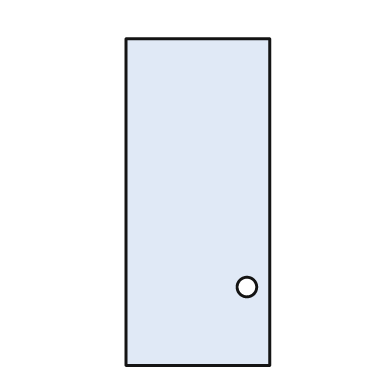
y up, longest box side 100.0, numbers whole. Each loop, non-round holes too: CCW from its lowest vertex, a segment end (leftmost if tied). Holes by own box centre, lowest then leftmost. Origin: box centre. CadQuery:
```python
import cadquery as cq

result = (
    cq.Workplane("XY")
    .moveTo(-22.0, -50.0)
    .lineTo(22.0, -50.0)
    .lineTo(22.0, 50.0)
    .lineTo(-22.0, 50.0)
    .close()
    .moveTo(15.0, -26.0)
    .circle(3.0)
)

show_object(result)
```